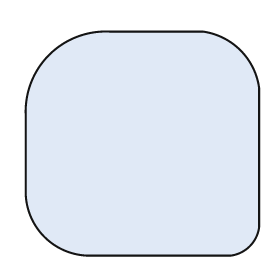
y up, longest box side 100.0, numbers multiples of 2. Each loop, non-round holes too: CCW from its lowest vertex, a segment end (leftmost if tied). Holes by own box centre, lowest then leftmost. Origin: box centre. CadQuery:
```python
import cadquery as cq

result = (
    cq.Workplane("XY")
    .moveTo(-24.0, -48.0)
    .lineTo(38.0, -48.0)
    .threePointArc((46.0, -44.0), (50.0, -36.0))
    .lineTo(50.0, 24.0)
    .threePointArc((42.0, 40.0), (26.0, 48.0))
    .lineTo(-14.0, 48.0)
    .threePointArc((-40.0, 38.0), (-50.0, 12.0))
    .lineTo(-50.0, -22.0)
    .threePointArc((-42.0, -40.0), (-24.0, -48.0))
    .close()
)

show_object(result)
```